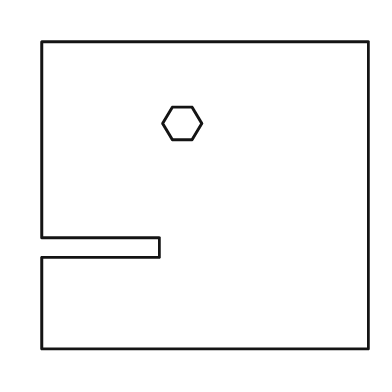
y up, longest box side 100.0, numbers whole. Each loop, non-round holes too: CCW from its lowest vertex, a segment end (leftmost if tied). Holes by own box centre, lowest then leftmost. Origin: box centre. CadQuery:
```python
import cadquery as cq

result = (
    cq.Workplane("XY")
    .moveTo(-50.0, -47.0)
    .lineTo(50.0, -47.0)
    .lineTo(50.0, 47.0)
    .lineTo(-50.0, 47.0)
    .lineTo(-50.0, -13.0)
    .lineTo(-14.0, -13.0)
    .lineTo(-14.0, -19.0)
    .lineTo(-50.0, -19.0)
    .close()
    .moveTo(-10.0, 17.0)
    .lineTo(-4.0, 17.0)
    .lineTo(-1.0, 22.0)
    .lineTo(-4.0, 27.0)
    .lineTo(-10.0, 27.0)
    .lineTo(-13.0, 22.0)
    .close()
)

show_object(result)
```